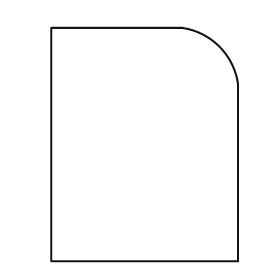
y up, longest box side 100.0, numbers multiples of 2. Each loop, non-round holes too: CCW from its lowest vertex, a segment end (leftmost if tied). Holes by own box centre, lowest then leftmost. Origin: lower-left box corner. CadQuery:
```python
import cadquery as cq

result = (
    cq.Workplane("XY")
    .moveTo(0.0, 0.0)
    .lineTo(80.0, 0.0)
    .lineTo(80.0, 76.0)
    .threePointArc((72.0, 92.0), (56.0, 100.0))
    .lineTo(0.0, 100.0)
    .close()
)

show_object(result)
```